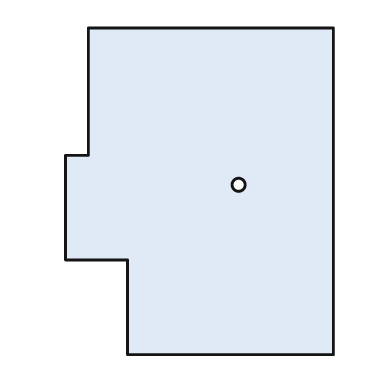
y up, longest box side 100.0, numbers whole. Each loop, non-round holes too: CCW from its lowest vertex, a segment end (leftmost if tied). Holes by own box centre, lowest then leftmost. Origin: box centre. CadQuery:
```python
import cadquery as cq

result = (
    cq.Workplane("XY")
    .moveTo(-22.0, -50.0)
    .lineTo(41.0, -50.0)
    .lineTo(41.0, 50.0)
    .lineTo(-34.0, 50.0)
    .lineTo(-34.0, 11.0)
    .lineTo(-41.0, 11.0)
    .lineTo(-41.0, -21.0)
    .lineTo(-22.0, -21.0)
    .close()
    .moveTo(12.0, 2.0)
    .circle(2.0)
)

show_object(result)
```